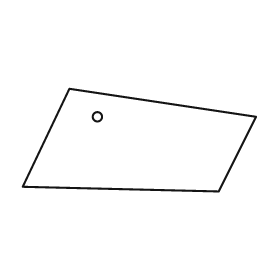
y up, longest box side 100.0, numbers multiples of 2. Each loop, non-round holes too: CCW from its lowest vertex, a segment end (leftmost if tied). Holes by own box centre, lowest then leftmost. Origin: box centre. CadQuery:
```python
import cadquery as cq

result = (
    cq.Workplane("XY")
    .moveTo(34.0, -22.0)
    .lineTo(50.0, 10.0)
    .lineTo(-30.0, 22.0)
    .lineTo(-50.0, -20.0)
    .close()
    .moveTo(-18.0, 10.0)
    .circle(2.0)
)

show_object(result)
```